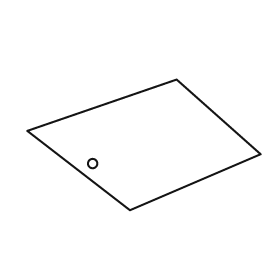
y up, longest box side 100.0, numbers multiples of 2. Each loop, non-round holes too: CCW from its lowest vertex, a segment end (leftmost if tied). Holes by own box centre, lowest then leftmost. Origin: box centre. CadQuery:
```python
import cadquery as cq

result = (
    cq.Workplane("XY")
    .moveTo(-6.0, -28.0)
    .lineTo(50.0, -4.0)
    .lineTo(14.0, 28.0)
    .lineTo(-50.0, 6.0)
    .close()
    .moveTo(-22.0, -8.0)
    .circle(2.0)
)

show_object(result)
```